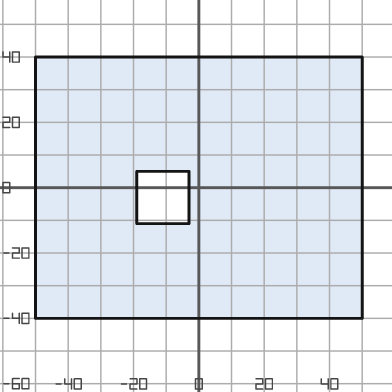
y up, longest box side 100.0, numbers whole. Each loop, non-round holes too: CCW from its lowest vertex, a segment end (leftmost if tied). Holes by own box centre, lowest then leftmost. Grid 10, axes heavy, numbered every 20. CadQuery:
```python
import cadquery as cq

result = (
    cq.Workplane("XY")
    .moveTo(-50.0, -40.0)
    .lineTo(50.0, -40.0)
    .lineTo(50.0, 40.0)
    .lineTo(-50.0, 40.0)
    .close()
    .moveTo(-19.0, -11.0)
    .lineTo(-3.0, -11.0)
    .lineTo(-3.0, 5.0)
    .lineTo(-19.0, 5.0)
    .close()
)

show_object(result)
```